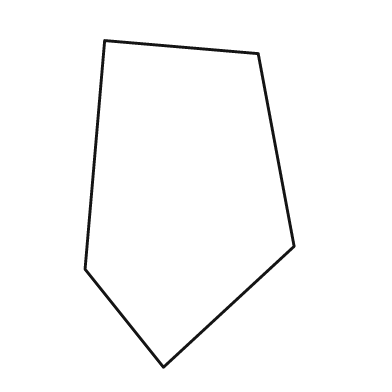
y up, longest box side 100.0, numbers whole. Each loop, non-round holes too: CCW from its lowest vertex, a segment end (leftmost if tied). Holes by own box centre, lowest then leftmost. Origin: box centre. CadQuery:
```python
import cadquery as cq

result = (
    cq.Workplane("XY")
    .moveTo(-8.0, -50.0)
    .lineTo(32.0, -13.0)
    .lineTo(21.0, 46.0)
    .lineTo(-26.0, 50.0)
    .lineTo(-32.0, -20.0)
    .close()
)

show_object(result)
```